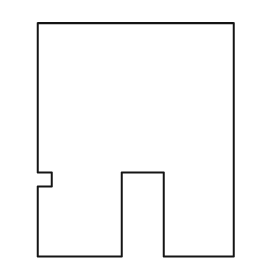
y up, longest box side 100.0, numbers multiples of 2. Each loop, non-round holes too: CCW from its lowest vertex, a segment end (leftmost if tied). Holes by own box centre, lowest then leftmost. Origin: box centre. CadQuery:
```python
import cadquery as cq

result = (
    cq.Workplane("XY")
    .moveTo(-42.0, -50.0)
    .lineTo(-6.0, -50.0)
    .lineTo(-6.0, -14.0)
    .lineTo(12.0, -14.0)
    .lineTo(12.0, -50.0)
    .lineTo(42.0, -50.0)
    .lineTo(42.0, 50.0)
    .lineTo(-42.0, 50.0)
    .lineTo(-42.0, -14.0)
    .lineTo(-36.0, -14.0)
    .lineTo(-36.0, -20.0)
    .lineTo(-42.0, -20.0)
    .close()
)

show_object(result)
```